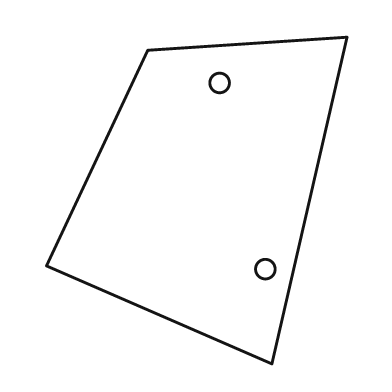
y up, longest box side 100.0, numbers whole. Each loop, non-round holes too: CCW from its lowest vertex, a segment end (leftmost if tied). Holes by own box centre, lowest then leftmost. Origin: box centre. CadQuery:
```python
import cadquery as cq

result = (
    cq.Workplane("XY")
    .moveTo(23.0, -50.0)
    .lineTo(46.0, 50.0)
    .lineTo(-15.0, 46.0)
    .lineTo(-46.0, -20.0)
    .close()
    .moveTo(21.0, -21.0)
    .circle(3.0)
    .moveTo(7.0, 36.0)
    .circle(3.0)
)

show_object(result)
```